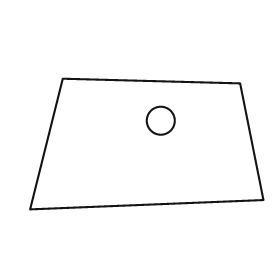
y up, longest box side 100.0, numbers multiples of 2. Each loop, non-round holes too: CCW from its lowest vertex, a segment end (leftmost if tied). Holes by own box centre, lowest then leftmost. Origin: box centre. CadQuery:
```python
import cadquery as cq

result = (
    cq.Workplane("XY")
    .moveTo(-50.0, -28.0)
    .lineTo(50.0, -24.0)
    .lineTo(40.0, 26.0)
    .lineTo(-36.0, 28.0)
    .close()
    .moveTo(6.0, 10.0)
    .circle(6.0)
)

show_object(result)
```